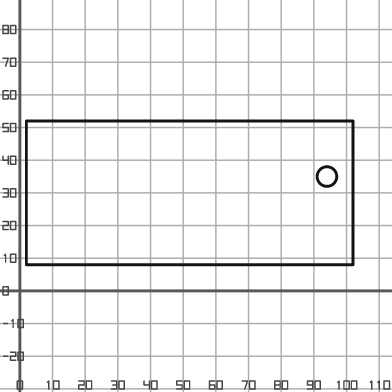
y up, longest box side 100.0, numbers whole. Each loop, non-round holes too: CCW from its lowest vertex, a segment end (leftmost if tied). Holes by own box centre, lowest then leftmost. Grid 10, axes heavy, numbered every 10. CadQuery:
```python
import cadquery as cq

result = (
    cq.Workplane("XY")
    .moveTo(2.0, 8.0)
    .lineTo(102.0, 8.0)
    .lineTo(102.0, 52.0)
    .lineTo(2.0, 52.0)
    .close()
    .moveTo(94.0, 35.0)
    .circle(3.0)
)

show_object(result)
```